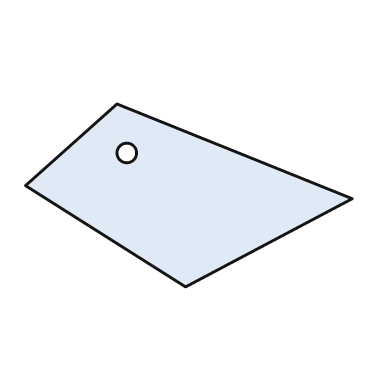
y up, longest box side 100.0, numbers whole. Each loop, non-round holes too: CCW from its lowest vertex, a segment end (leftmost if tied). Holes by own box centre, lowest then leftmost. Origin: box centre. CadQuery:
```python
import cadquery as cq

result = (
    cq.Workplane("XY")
    .moveTo(-1.0, -28.0)
    .lineTo(50.0, -1.0)
    .lineTo(-22.0, 28.0)
    .lineTo(-50.0, 3.0)
    .close()
    .moveTo(-19.0, 13.0)
    .circle(3.0)
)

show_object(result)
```